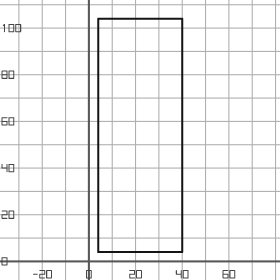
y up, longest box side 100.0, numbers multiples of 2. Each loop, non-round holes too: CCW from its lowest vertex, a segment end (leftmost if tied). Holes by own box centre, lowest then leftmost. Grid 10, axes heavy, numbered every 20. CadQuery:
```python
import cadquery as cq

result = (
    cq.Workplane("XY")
    .moveTo(4.0, 4.0)
    .lineTo(40.0, 4.0)
    .lineTo(40.0, 104.0)
    .lineTo(4.0, 104.0)
    .close()
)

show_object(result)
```